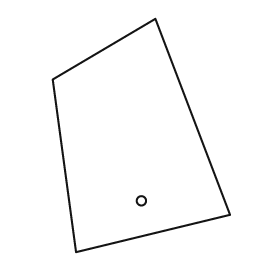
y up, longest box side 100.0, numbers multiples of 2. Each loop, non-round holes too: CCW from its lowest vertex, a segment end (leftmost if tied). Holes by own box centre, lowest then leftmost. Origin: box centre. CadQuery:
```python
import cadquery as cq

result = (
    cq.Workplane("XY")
    .moveTo(-28.0, -50.0)
    .lineTo(38.0, -34.0)
    .lineTo(6.0, 50.0)
    .lineTo(-38.0, 24.0)
    .close()
    .moveTo(0.0, -28.0)
    .circle(2.0)
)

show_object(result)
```